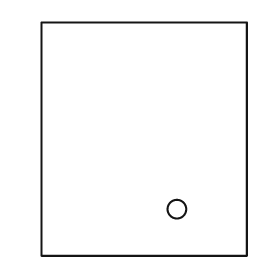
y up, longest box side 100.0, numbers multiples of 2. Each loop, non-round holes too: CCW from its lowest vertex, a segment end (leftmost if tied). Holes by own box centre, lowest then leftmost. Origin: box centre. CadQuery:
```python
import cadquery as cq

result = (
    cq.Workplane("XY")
    .moveTo(-44.0, -50.0)
    .lineTo(44.0, -50.0)
    .lineTo(44.0, 50.0)
    .lineTo(-44.0, 50.0)
    .close()
    .moveTo(14.0, -30.0)
    .circle(4.0)
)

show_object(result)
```